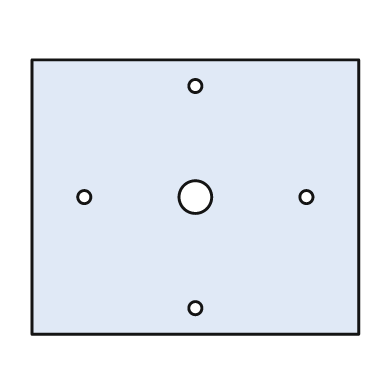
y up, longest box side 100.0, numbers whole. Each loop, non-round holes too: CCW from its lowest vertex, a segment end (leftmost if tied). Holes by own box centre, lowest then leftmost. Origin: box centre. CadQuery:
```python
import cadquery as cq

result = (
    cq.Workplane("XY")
    .moveTo(-50.0, -42.0)
    .lineTo(50.0, -42.0)
    .lineTo(50.0, 42.0)
    .lineTo(-50.0, 42.0)
    .close()
    .moveTo(0.0, -34.0)
    .circle(2.0)
    .moveTo(-34.0, 0.0)
    .circle(2.0)
    .moveTo(0.0, 0.0)
    .circle(5.0)
    .moveTo(34.0, 0.0)
    .circle(2.0)
    .moveTo(0.0, 34.0)
    .circle(2.0)
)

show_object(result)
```